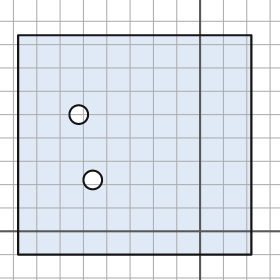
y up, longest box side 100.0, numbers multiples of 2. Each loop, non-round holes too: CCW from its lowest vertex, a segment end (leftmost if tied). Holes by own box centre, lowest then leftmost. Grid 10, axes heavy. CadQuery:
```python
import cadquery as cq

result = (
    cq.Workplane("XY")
    .moveTo(-78.0, -10.0)
    .lineTo(22.0, -10.0)
    .lineTo(22.0, 84.0)
    .lineTo(-78.0, 84.0)
    .close()
    .moveTo(-46.0, 22.0)
    .circle(4.0)
    .moveTo(-52.0, 50.0)
    .circle(4.0)
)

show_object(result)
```